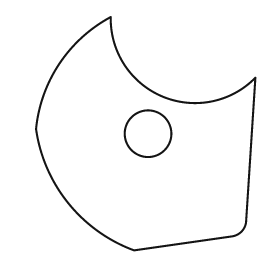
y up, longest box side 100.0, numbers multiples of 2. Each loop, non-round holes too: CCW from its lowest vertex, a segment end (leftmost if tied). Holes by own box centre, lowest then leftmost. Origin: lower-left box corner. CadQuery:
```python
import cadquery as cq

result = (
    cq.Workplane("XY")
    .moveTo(42.0, 0.0)
    .lineTo(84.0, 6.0)
    .threePointArc((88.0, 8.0), (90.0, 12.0))
    .lineTo(94.0, 74.0)
    .threePointArc((54.0, 66.0), (32.0, 100.0))
    .threePointArc((10.0, 80.0), (0.0, 52.0))
    .threePointArc((14.0, 20.0), (42.0, 0.0))
    .close()
    .moveTo(48.0, 50.0)
    .circle(10.0)
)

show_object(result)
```